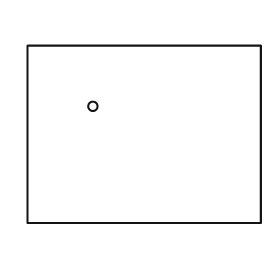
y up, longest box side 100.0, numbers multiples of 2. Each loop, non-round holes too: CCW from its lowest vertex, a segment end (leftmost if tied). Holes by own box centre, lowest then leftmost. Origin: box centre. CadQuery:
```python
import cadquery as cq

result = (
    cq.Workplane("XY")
    .moveTo(-50.0, -38.0)
    .lineTo(50.0, -38.0)
    .lineTo(50.0, 38.0)
    .lineTo(-50.0, 38.0)
    .close()
    .moveTo(-22.0, 12.0)
    .circle(2.0)
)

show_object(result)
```